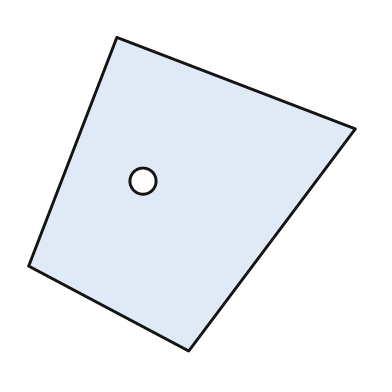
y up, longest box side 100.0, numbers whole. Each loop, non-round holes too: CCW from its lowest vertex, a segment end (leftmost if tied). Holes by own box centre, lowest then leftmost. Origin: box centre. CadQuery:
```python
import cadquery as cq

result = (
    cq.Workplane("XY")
    .moveTo(-1.0, -48.0)
    .lineTo(50.0, 20.0)
    .lineTo(-23.0, 48.0)
    .lineTo(-50.0, -22.0)
    .close()
    .moveTo(-15.0, 4.0)
    .circle(4.0)
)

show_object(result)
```